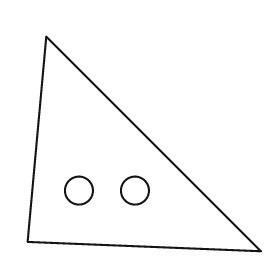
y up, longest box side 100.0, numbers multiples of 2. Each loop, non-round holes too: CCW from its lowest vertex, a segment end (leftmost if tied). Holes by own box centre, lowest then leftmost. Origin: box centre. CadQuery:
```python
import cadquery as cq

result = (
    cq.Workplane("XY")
    .moveTo(50.0, -46.0)
    .lineTo(-42.0, 46.0)
    .lineTo(-50.0, -42.0)
    .close()
    .moveTo(-28.0, -20.0)
    .circle(6.0)
    .moveTo(-4.0, -20.0)
    .circle(6.0)
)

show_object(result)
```